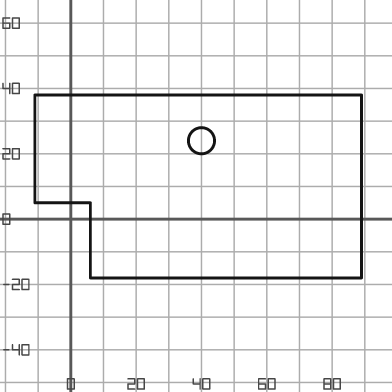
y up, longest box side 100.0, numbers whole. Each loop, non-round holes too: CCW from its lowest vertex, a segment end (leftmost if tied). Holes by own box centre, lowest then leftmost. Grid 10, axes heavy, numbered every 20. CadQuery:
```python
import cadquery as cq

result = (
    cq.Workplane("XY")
    .moveTo(6.0, -18.0)
    .lineTo(89.0, -18.0)
    .lineTo(89.0, 38.0)
    .lineTo(-11.0, 38.0)
    .lineTo(-11.0, 5.0)
    .lineTo(6.0, 5.0)
    .close()
    .moveTo(40.0, 24.0)
    .circle(4.0)
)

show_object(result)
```